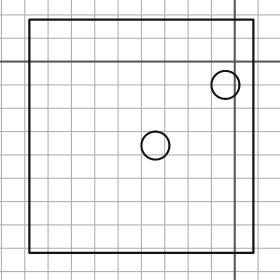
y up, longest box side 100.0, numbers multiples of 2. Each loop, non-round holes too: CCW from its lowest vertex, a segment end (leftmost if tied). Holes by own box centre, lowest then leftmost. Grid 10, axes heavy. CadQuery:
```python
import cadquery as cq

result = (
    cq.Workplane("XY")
    .moveTo(-88.0, -82.0)
    .lineTo(8.0, -82.0)
    .lineTo(8.0, 18.0)
    .lineTo(-88.0, 18.0)
    .close()
    .moveTo(-34.0, -36.0)
    .circle(6.0)
    .moveTo(-4.0, -10.0)
    .circle(6.0)
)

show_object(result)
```